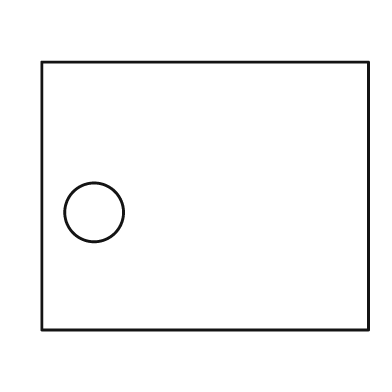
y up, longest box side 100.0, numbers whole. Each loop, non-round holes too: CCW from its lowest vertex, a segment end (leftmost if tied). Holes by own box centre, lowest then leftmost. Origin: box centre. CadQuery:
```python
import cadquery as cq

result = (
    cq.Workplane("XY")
    .moveTo(-50.0, -41.0)
    .lineTo(50.0, -41.0)
    .lineTo(50.0, 41.0)
    .lineTo(-50.0, 41.0)
    .close()
    .moveTo(-34.0, -5.0)
    .circle(9.0)
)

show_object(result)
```